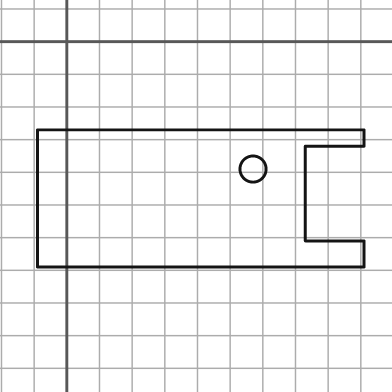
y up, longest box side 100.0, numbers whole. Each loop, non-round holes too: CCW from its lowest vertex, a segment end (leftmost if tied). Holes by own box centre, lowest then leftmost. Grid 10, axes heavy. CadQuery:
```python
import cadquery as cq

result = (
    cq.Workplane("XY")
    .moveTo(-9.0, -69.0)
    .lineTo(91.0, -69.0)
    .lineTo(91.0, -61.0)
    .lineTo(73.0, -61.0)
    .lineTo(73.0, -32.0)
    .lineTo(91.0, -32.0)
    .lineTo(91.0, -27.0)
    .lineTo(-9.0, -27.0)
    .close()
    .moveTo(57.0, -39.0)
    .circle(4.0)
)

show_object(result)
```